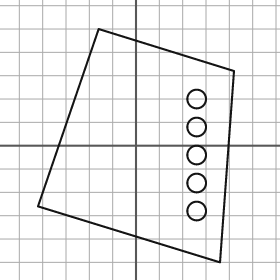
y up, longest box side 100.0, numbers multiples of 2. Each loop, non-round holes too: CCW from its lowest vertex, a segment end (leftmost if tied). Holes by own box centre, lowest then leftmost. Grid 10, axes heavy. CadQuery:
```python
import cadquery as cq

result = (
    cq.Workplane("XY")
    .moveTo(36.0, -50.0)
    .lineTo(42.0, 32.0)
    .lineTo(-16.0, 50.0)
    .lineTo(-42.0, -26.0)
    .close()
    .moveTo(26.0, -28.0)
    .circle(4.0)
    .moveTo(26.0, -16.0)
    .circle(4.0)
    .moveTo(26.0, -4.0)
    .circle(4.0)
    .moveTo(26.0, 8.0)
    .circle(4.0)
    .moveTo(26.0, 20.0)
    .circle(4.0)
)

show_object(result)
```